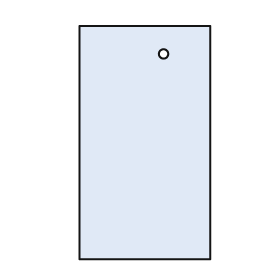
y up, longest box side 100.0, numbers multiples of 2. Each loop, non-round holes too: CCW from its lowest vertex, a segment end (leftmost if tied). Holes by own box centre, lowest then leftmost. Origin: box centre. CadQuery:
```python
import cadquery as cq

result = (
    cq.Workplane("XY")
    .moveTo(-28.0, -50.0)
    .lineTo(28.0, -50.0)
    .lineTo(28.0, 50.0)
    .lineTo(-28.0, 50.0)
    .close()
    .moveTo(8.0, 38.0)
    .circle(2.0)
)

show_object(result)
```